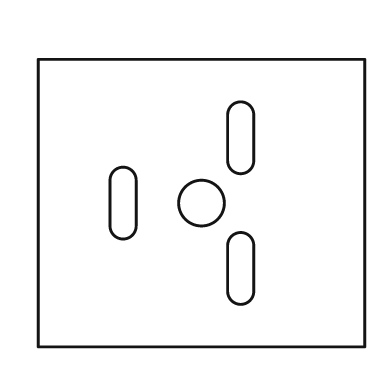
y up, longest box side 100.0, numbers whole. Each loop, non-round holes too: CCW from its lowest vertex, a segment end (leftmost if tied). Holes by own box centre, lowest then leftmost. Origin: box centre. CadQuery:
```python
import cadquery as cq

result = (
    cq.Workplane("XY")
    .moveTo(-50.0, -44.0)
    .lineTo(50.0, -44.0)
    .lineTo(50.0, 44.0)
    .lineTo(-50.0, 44.0)
    .close()
    .moveTo(8.0, -27.0)
    .threePointArc((12.0, -31.0), (16.0, -27.0))
    .lineTo(16.0, -13.0)
    .threePointArc((12.0, -9.0), (8.0, -13.0))
    .close()
    .moveTo(-28.0, -7.0)
    .threePointArc((-24.0, -11.0), (-20.0, -7.0))
    .lineTo(-20.0, 7.0)
    .threePointArc((-24.0, 11.0), (-28.0, 7.0))
    .close()
    .moveTo(0.0, 0.0)
    .circle(7.0)
    .moveTo(8.0, 13.0)
    .threePointArc((12.0, 9.0), (16.0, 13.0))
    .lineTo(16.0, 27.0)
    .threePointArc((12.0, 31.0), (8.0, 27.0))
    .close()
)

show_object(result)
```